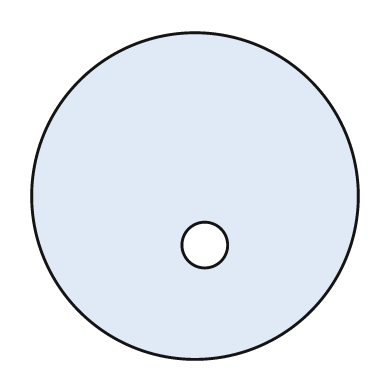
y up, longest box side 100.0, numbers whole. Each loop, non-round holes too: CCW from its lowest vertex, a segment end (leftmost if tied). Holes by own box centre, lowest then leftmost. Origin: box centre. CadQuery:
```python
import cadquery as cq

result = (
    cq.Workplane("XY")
    .moveTo(0.0, 0.0)
    .circle(50.0)
    .moveTo(3.0, -15.0)
    .circle(7.0)
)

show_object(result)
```